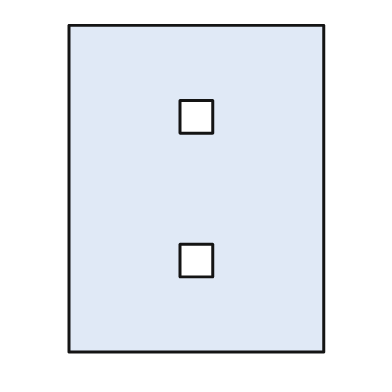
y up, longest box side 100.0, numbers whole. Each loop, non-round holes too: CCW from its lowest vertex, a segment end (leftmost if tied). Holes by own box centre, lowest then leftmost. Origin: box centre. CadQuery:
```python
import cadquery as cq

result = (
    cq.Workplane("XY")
    .moveTo(-39.0, -50.0)
    .lineTo(39.0, -50.0)
    .lineTo(39.0, 50.0)
    .lineTo(-39.0, 50.0)
    .close()
    .moveTo(-5.0, -27.0)
    .lineTo(5.0, -27.0)
    .lineTo(5.0, -17.0)
    .lineTo(-5.0, -17.0)
    .close()
    .moveTo(-5.0, 17.0)
    .lineTo(5.0, 17.0)
    .lineTo(5.0, 27.0)
    .lineTo(-5.0, 27.0)
    .close()
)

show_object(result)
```